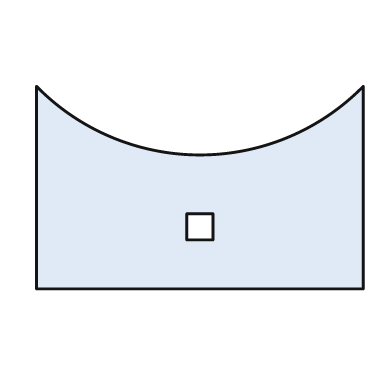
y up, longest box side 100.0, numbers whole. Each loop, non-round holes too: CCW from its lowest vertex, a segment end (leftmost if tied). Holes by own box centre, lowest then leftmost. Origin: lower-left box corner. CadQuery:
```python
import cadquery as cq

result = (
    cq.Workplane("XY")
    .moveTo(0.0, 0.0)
    .lineTo(100.0, 0.0)
    .lineTo(100.0, 62.0)
    .threePointArc((50.0, 41.0), (0.0, 62.0))
    .close()
    .moveTo(46.0, 15.0)
    .lineTo(54.0, 15.0)
    .lineTo(54.0, 23.0)
    .lineTo(46.0, 23.0)
    .close()
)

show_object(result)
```